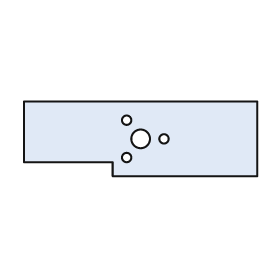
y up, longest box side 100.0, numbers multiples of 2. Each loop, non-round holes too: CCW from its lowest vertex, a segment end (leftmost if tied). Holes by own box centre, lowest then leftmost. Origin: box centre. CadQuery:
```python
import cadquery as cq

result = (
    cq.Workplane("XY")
    .moveTo(-12.0, -16.0)
    .lineTo(50.0, -16.0)
    .lineTo(50.0, 16.0)
    .lineTo(-50.0, 16.0)
    .lineTo(-50.0, -10.0)
    .lineTo(-12.0, -10.0)
    .close()
    .moveTo(-6.0, -8.0)
    .circle(2.0)
    .moveTo(0.0, 0.0)
    .circle(4.0)
    .moveTo(10.0, 0.0)
    .circle(2.0)
    .moveTo(-6.0, 8.0)
    .circle(2.0)
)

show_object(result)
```